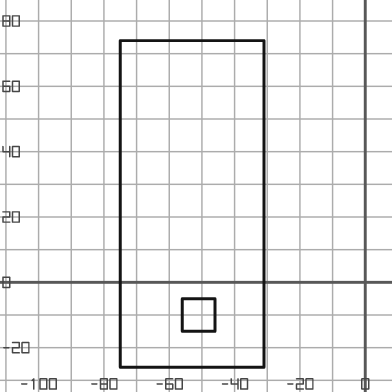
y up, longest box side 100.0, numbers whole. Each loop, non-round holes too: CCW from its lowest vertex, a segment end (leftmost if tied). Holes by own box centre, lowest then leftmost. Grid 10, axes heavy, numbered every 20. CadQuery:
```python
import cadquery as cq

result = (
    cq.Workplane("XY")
    .moveTo(-75.0, -26.0)
    .lineTo(-31.0, -26.0)
    .lineTo(-31.0, 74.0)
    .lineTo(-75.0, 74.0)
    .close()
    .moveTo(-56.0, -15.0)
    .lineTo(-46.0, -15.0)
    .lineTo(-46.0, -5.0)
    .lineTo(-56.0, -5.0)
    .close()
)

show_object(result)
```